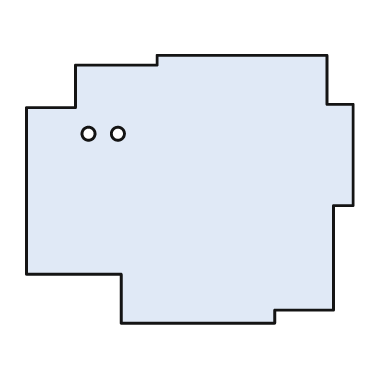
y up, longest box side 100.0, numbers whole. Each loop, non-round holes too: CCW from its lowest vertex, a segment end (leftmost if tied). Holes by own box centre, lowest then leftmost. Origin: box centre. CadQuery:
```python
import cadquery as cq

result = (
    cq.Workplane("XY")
    .moveTo(-21.0, -41.0)
    .lineTo(26.0, -41.0)
    .lineTo(26.0, -37.0)
    .lineTo(44.0, -37.0)
    .lineTo(44.0, -5.0)
    .lineTo(50.0, -5.0)
    .lineTo(50.0, 26.0)
    .lineTo(42.0, 26.0)
    .lineTo(42.0, 41.0)
    .lineTo(-10.0, 41.0)
    .lineTo(-10.0, 38.0)
    .lineTo(-35.0, 38.0)
    .lineTo(-35.0, 25.0)
    .lineTo(-50.0, 25.0)
    .lineTo(-50.0, -26.0)
    .lineTo(-21.0, -26.0)
    .close()
    .moveTo(-31.0, 17.0)
    .circle(2.0)
    .moveTo(-22.0, 17.0)
    .circle(2.0)
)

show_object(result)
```